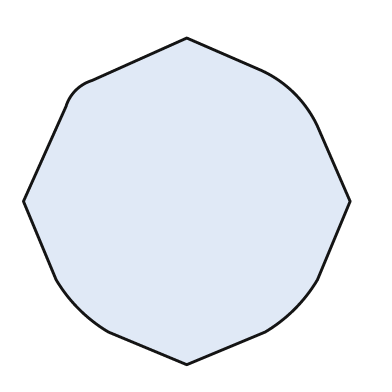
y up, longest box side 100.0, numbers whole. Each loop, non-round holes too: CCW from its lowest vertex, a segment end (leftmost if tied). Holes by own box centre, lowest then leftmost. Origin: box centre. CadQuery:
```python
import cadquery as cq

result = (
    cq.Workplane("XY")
    .moveTo(0.0, -50.0)
    .lineTo(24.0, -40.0)
    .threePointArc((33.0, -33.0), (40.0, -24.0))
    .lineTo(50.0, 0.0)
    .lineTo(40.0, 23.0)
    .threePointArc((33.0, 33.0), (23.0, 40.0))
    .lineTo(0.0, 50.0)
    .lineTo(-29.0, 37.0)
    .threePointArc((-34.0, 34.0), (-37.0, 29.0))
    .lineTo(-50.0, 0.0)
    .lineTo(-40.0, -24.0)
    .threePointArc((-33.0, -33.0), (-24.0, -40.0))
    .close()
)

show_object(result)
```